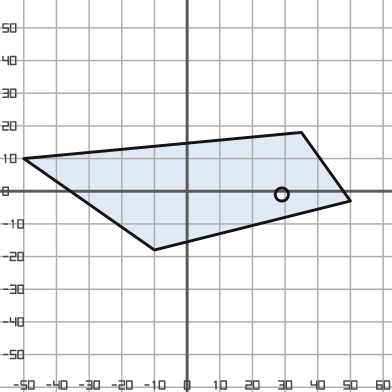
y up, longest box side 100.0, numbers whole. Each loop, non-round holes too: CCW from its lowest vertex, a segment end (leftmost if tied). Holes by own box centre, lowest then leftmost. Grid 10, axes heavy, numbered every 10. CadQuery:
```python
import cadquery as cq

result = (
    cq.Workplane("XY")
    .moveTo(-10.0, -18.0)
    .lineTo(50.0, -3.0)
    .lineTo(35.0, 18.0)
    .lineTo(-50.0, 10.0)
    .close()
    .moveTo(29.0, -1.0)
    .circle(2.0)
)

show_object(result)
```